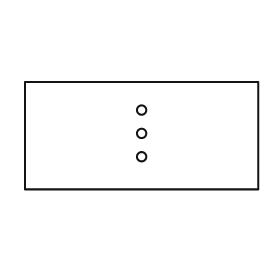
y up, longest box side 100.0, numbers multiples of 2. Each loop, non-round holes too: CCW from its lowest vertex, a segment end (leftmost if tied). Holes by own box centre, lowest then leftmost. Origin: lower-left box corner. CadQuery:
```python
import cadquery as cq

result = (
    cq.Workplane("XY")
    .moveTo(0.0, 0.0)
    .lineTo(100.0, 0.0)
    .lineTo(100.0, 46.0)
    .lineTo(0.0, 46.0)
    .close()
    .moveTo(50.0, 14.0)
    .circle(2.0)
    .moveTo(50.0, 24.0)
    .circle(2.0)
    .moveTo(50.0, 34.0)
    .circle(2.0)
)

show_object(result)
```